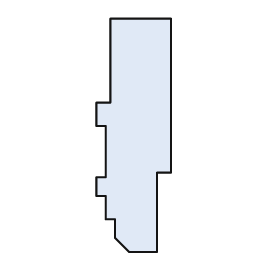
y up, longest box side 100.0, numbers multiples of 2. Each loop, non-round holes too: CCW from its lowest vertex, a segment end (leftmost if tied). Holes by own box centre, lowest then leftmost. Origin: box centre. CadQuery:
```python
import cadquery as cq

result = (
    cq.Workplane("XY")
    .moveTo(-2.0, -50.0)
    .lineTo(10.0, -50.0)
    .lineTo(10.0, -16.0)
    .lineTo(16.0, -16.0)
    .lineTo(16.0, 50.0)
    .lineTo(-10.0, 50.0)
    .lineTo(-10.0, 14.0)
    .lineTo(-16.0, 14.0)
    .lineTo(-16.0, 4.0)
    .lineTo(-12.0, 4.0)
    .lineTo(-12.0, -18.0)
    .lineTo(-16.0, -18.0)
    .lineTo(-16.0, -26.0)
    .lineTo(-12.0, -26.0)
    .lineTo(-12.0, -36.0)
    .lineTo(-8.0, -36.0)
    .lineTo(-8.0, -44.0)
    .close()
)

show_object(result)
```